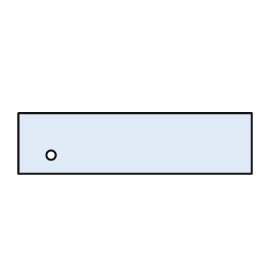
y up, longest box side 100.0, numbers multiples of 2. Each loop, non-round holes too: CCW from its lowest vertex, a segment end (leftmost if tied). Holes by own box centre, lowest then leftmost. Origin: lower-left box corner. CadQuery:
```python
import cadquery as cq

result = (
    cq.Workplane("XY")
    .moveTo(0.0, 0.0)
    .lineTo(100.0, 0.0)
    .lineTo(100.0, 26.0)
    .lineTo(0.0, 26.0)
    .close()
    .moveTo(14.0, 8.0)
    .circle(2.0)
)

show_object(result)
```